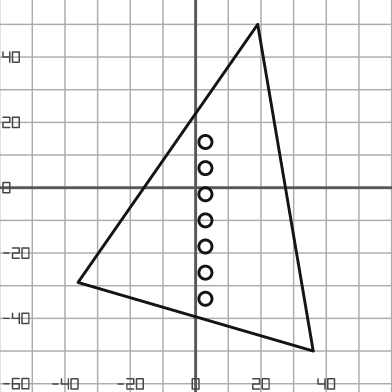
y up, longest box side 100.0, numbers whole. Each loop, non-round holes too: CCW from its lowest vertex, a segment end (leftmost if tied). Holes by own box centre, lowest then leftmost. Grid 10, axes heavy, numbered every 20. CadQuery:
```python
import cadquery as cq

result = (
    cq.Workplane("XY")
    .moveTo(36.0, -50.0)
    .lineTo(19.0, 50.0)
    .lineTo(-36.0, -29.0)
    .close()
    .moveTo(3.0, -34.0)
    .circle(2.0)
    .moveTo(3.0, -26.0)
    .circle(2.0)
    .moveTo(3.0, -18.0)
    .circle(2.0)
    .moveTo(3.0, -10.0)
    .circle(2.0)
    .moveTo(3.0, -2.0)
    .circle(2.0)
    .moveTo(3.0, 6.0)
    .circle(2.0)
    .moveTo(3.0, 14.0)
    .circle(2.0)
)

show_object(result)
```